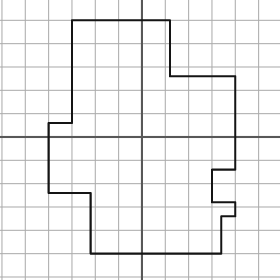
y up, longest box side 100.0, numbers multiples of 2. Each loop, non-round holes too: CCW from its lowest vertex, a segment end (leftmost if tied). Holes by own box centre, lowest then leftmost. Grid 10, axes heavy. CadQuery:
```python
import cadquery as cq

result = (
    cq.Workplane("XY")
    .moveTo(-22.0, -50.0)
    .lineTo(34.0, -50.0)
    .lineTo(34.0, -34.0)
    .lineTo(40.0, -34.0)
    .lineTo(40.0, -28.0)
    .lineTo(30.0, -28.0)
    .lineTo(30.0, -14.0)
    .lineTo(40.0, -14.0)
    .lineTo(40.0, 26.0)
    .lineTo(12.0, 26.0)
    .lineTo(12.0, 50.0)
    .lineTo(-30.0, 50.0)
    .lineTo(-30.0, 6.0)
    .lineTo(-40.0, 6.0)
    .lineTo(-40.0, -24.0)
    .lineTo(-22.0, -24.0)
    .close()
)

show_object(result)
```